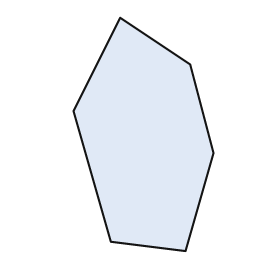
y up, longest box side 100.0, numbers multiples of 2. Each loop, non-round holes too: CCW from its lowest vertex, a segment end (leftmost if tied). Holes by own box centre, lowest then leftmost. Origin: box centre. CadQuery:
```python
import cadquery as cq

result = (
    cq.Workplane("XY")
    .moveTo(18.0, -50.0)
    .lineTo(30.0, -8.0)
    .lineTo(20.0, 30.0)
    .lineTo(-10.0, 50.0)
    .lineTo(-30.0, 10.0)
    .lineTo(-14.0, -46.0)
    .close()
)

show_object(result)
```